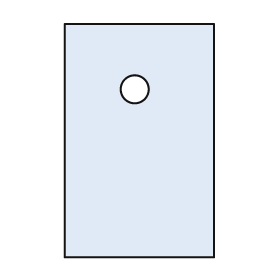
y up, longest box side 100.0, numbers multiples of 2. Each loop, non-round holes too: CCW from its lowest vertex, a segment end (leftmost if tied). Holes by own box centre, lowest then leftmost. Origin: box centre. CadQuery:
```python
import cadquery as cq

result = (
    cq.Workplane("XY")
    .moveTo(-32.0, -50.0)
    .lineTo(32.0, -50.0)
    .lineTo(32.0, 50.0)
    .lineTo(-32.0, 50.0)
    .close()
    .moveTo(-2.0, 22.0)
    .circle(6.0)
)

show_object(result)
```